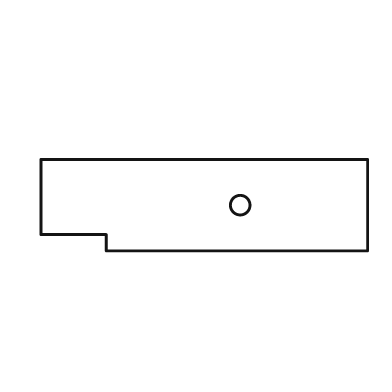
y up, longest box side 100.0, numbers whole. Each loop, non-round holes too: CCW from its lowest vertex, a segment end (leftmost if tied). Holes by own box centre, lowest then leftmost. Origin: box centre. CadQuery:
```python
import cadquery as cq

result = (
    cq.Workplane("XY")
    .moveTo(-30.0, -14.0)
    .lineTo(50.0, -14.0)
    .lineTo(50.0, 14.0)
    .lineTo(-50.0, 14.0)
    .lineTo(-50.0, -9.0)
    .lineTo(-30.0, -9.0)
    .close()
    .moveTo(11.0, 0.0)
    .circle(3.0)
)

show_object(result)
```